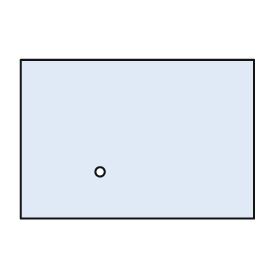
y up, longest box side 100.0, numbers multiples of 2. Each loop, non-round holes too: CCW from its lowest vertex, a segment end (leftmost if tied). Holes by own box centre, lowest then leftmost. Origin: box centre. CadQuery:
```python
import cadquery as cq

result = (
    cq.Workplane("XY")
    .moveTo(-50.0, -34.0)
    .lineTo(50.0, -34.0)
    .lineTo(50.0, 34.0)
    .lineTo(-50.0, 34.0)
    .close()
    .moveTo(-16.0, -14.0)
    .circle(2.0)
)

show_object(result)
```